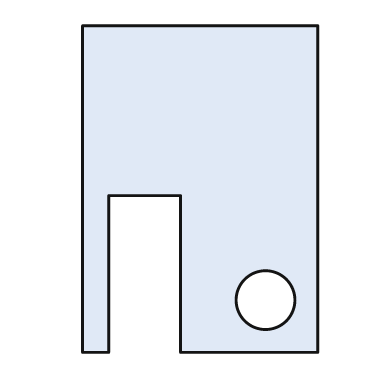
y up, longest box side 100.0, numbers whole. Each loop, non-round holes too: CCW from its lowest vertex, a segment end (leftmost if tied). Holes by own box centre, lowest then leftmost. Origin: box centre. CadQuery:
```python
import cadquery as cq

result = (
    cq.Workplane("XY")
    .moveTo(-36.0, -50.0)
    .lineTo(-28.0, -50.0)
    .lineTo(-28.0, -2.0)
    .lineTo(-6.0, -2.0)
    .lineTo(-6.0, -50.0)
    .lineTo(36.0, -50.0)
    .lineTo(36.0, 50.0)
    .lineTo(-36.0, 50.0)
    .close()
    .moveTo(20.0, -34.0)
    .circle(9.0)
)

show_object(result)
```